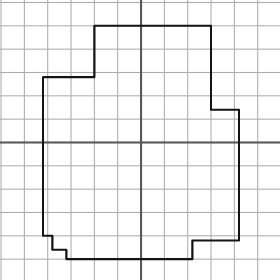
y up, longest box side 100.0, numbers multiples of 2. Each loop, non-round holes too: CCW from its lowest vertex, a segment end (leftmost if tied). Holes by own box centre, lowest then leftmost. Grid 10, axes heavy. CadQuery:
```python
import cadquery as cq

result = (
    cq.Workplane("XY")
    .moveTo(-32.0, -50.0)
    .lineTo(22.0, -50.0)
    .lineTo(22.0, -42.0)
    .lineTo(42.0, -42.0)
    .lineTo(42.0, 14.0)
    .lineTo(30.0, 14.0)
    .lineTo(30.0, 50.0)
    .lineTo(-20.0, 50.0)
    .lineTo(-20.0, 28.0)
    .lineTo(-42.0, 28.0)
    .lineTo(-42.0, -40.0)
    .lineTo(-38.0, -40.0)
    .lineTo(-38.0, -46.0)
    .lineTo(-32.0, -46.0)
    .close()
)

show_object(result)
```